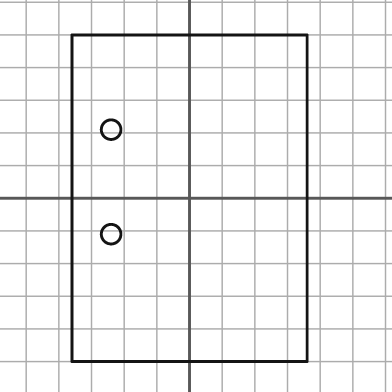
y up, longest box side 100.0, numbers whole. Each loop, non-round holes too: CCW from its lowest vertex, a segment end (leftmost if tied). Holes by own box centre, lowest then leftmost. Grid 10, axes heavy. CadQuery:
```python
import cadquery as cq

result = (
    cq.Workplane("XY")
    .moveTo(-36.0, -50.0)
    .lineTo(36.0, -50.0)
    .lineTo(36.0, 50.0)
    .lineTo(-36.0, 50.0)
    .close()
    .moveTo(-24.0, -11.0)
    .circle(3.0)
    .moveTo(-24.0, 21.0)
    .circle(3.0)
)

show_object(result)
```